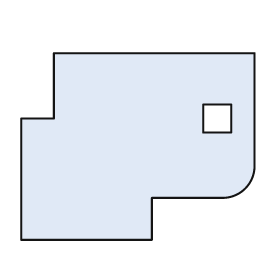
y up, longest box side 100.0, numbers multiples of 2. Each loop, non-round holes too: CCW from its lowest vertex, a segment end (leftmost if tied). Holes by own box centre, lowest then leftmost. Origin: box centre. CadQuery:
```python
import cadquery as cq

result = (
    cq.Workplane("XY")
    .moveTo(-50.0, -40.0)
    .lineTo(6.0, -40.0)
    .lineTo(6.0, -22.0)
    .lineTo(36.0, -22.0)
    .threePointArc((46.0, -18.0), (50.0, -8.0))
    .lineTo(50.0, 40.0)
    .lineTo(-36.0, 40.0)
    .lineTo(-36.0, 12.0)
    .lineTo(-50.0, 12.0)
    .close()
    .moveTo(28.0, 6.0)
    .lineTo(40.0, 6.0)
    .lineTo(40.0, 18.0)
    .lineTo(28.0, 18.0)
    .close()
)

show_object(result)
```